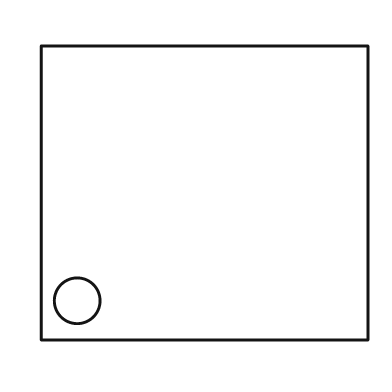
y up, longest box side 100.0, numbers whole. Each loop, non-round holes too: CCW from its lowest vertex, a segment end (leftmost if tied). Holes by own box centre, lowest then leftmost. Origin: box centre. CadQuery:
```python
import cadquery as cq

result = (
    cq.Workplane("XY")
    .moveTo(-50.0, -45.0)
    .lineTo(50.0, -45.0)
    .lineTo(50.0, 45.0)
    .lineTo(-50.0, 45.0)
    .close()
    .moveTo(-39.0, -33.0)
    .circle(7.0)
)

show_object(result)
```